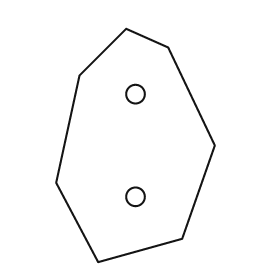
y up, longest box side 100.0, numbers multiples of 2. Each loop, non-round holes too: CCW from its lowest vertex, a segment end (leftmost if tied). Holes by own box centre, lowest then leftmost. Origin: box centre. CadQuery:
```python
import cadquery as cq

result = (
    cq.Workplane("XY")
    .moveTo(-16.0, -50.0)
    .lineTo(20.0, -40.0)
    .lineTo(34.0, 0.0)
    .lineTo(14.0, 42.0)
    .lineTo(-4.0, 50.0)
    .lineTo(-24.0, 30.0)
    .lineTo(-34.0, -16.0)
    .close()
    .moveTo(0.0, -22.0)
    .circle(4.0)
    .moveTo(0.0, 22.0)
    .circle(4.0)
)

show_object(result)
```